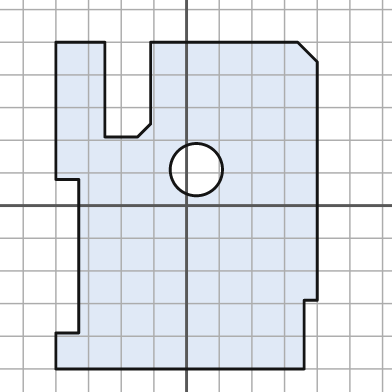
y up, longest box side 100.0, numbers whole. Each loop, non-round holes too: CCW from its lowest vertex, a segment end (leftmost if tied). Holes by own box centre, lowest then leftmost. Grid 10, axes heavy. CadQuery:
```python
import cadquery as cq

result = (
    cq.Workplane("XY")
    .moveTo(-40.0, -50.0)
    .lineTo(36.0, -50.0)
    .lineTo(36.0, -29.0)
    .lineTo(40.0, -29.0)
    .lineTo(40.0, 44.0)
    .lineTo(34.0, 50.0)
    .lineTo(-11.0, 50.0)
    .lineTo(-11.0, 25.0)
    .lineTo(-15.0, 21.0)
    .lineTo(-25.0, 21.0)
    .lineTo(-25.0, 50.0)
    .lineTo(-40.0, 50.0)
    .lineTo(-40.0, 8.0)
    .lineTo(-33.0, 8.0)
    .lineTo(-33.0, -39.0)
    .lineTo(-40.0, -39.0)
    .close()
    .moveTo(3.0, 11.0)
    .circle(8.0)
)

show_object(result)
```